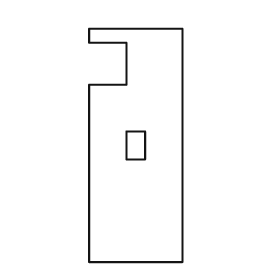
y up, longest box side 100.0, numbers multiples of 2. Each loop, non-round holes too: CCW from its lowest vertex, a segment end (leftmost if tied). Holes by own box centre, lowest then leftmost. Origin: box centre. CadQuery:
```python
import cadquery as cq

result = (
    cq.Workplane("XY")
    .moveTo(-20.0, -50.0)
    .lineTo(20.0, -50.0)
    .lineTo(20.0, 50.0)
    .lineTo(-20.0, 50.0)
    .lineTo(-20.0, 44.0)
    .lineTo(-4.0, 44.0)
    .lineTo(-4.0, 26.0)
    .lineTo(-20.0, 26.0)
    .close()
    .moveTo(-4.0, -6.0)
    .lineTo(4.0, -6.0)
    .lineTo(4.0, 6.0)
    .lineTo(-4.0, 6.0)
    .close()
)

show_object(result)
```